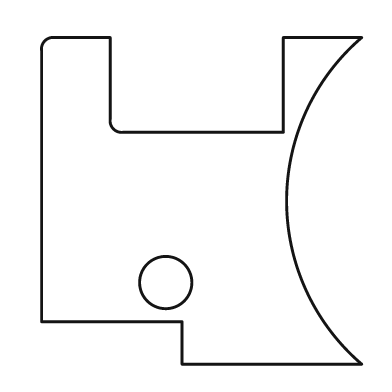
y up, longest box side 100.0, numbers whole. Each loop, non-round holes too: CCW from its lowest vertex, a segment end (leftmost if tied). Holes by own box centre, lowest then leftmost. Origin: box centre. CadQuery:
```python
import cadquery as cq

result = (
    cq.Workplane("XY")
    .moveTo(-6.0, -50.0)
    .lineTo(49.0, -50.0)
    .threePointArc((26.0, 0.0), (49.0, 50.0))
    .lineTo(25.0, 50.0)
    .lineTo(25.0, 21.0)
    .lineTo(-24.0, 21.0)
    .threePointArc((-27.0, 22.0), (-28.0, 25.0))
    .lineTo(-28.0, 50.0)
    .lineTo(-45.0, 50.0)
    .threePointArc((-48.0, 49.0), (-49.0, 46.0))
    .lineTo(-49.0, -37.0)
    .lineTo(-6.0, -37.0)
    .close()
    .moveTo(-11.0, -25.0)
    .circle(8.0)
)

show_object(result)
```